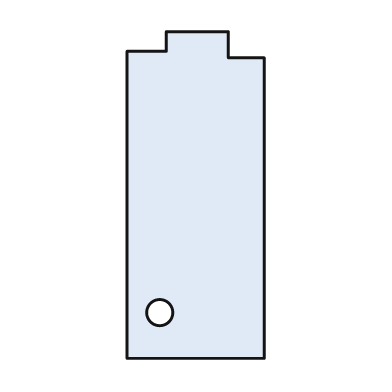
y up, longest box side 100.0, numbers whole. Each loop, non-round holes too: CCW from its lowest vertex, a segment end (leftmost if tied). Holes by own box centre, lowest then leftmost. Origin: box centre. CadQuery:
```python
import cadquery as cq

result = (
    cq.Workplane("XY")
    .moveTo(-21.0, -50.0)
    .lineTo(21.0, -50.0)
    .lineTo(21.0, 42.0)
    .lineTo(10.0, 42.0)
    .lineTo(10.0, 50.0)
    .lineTo(-9.0, 50.0)
    .lineTo(-9.0, 44.0)
    .lineTo(-21.0, 44.0)
    .close()
    .moveTo(-11.0, -36.0)
    .circle(4.0)
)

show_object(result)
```